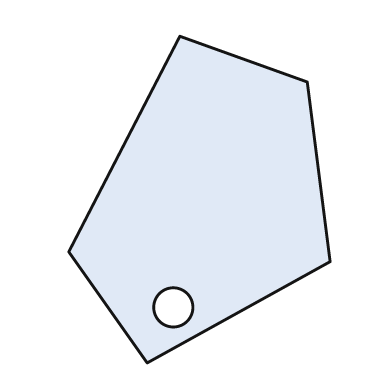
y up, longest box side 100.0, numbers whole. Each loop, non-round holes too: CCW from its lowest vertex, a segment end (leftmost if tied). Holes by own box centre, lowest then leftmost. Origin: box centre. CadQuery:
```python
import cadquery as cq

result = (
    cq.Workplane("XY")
    .moveTo(-16.0, -50.0)
    .lineTo(40.0, -19.0)
    .lineTo(33.0, 36.0)
    .lineTo(-6.0, 50.0)
    .lineTo(-40.0, -16.0)
    .close()
    .moveTo(-8.0, -33.0)
    .circle(6.0)
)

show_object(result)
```